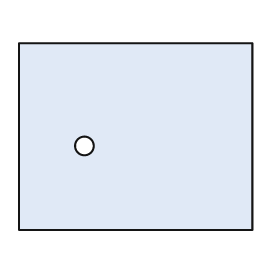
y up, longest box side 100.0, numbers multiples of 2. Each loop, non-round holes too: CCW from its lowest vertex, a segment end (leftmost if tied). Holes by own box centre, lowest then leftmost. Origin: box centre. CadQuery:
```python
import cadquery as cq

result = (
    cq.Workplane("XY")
    .moveTo(-50.0, -40.0)
    .lineTo(50.0, -40.0)
    .lineTo(50.0, 40.0)
    .lineTo(-50.0, 40.0)
    .close()
    .moveTo(-22.0, -4.0)
    .circle(4.0)
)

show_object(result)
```